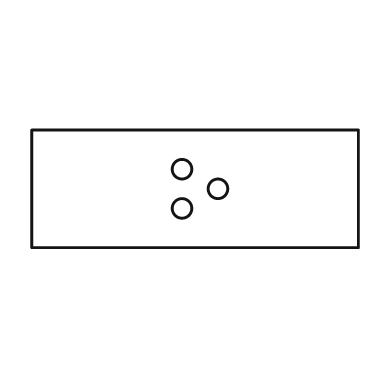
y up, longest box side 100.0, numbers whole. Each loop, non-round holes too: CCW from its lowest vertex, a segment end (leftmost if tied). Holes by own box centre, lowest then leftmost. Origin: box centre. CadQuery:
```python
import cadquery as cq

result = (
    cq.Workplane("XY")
    .moveTo(-50.0, -18.0)
    .lineTo(50.0, -18.0)
    .lineTo(50.0, 18.0)
    .lineTo(-50.0, 18.0)
    .close()
    .moveTo(-4.0, -6.0)
    .circle(3.0)
    .moveTo(7.0, 0.0)
    .circle(3.0)
    .moveTo(-4.0, 6.0)
    .circle(3.0)
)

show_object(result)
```